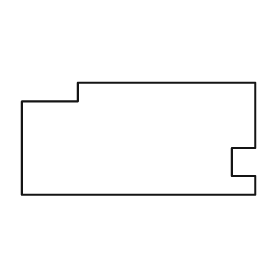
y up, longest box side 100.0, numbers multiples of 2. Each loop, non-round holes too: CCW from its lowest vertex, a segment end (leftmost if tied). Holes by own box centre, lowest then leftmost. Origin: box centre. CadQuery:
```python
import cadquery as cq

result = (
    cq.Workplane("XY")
    .moveTo(-50.0, -24.0)
    .lineTo(50.0, -24.0)
    .lineTo(50.0, -16.0)
    .lineTo(40.0, -16.0)
    .lineTo(40.0, -4.0)
    .lineTo(50.0, -4.0)
    .lineTo(50.0, 24.0)
    .lineTo(-26.0, 24.0)
    .lineTo(-26.0, 16.0)
    .lineTo(-50.0, 16.0)
    .close()
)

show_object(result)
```